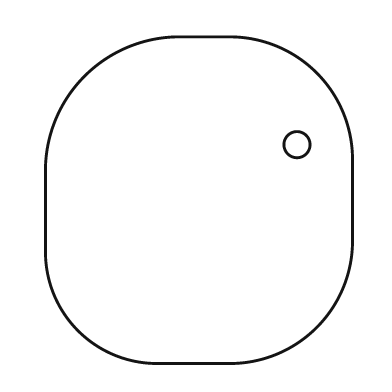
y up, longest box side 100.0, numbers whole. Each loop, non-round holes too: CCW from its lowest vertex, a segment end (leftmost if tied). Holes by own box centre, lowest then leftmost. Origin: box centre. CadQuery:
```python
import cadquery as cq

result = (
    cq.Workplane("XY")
    .moveTo(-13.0, -50.0)
    .lineTo(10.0, -50.0)
    .threePointArc((36.0, -39.0), (47.0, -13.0))
    .lineTo(47.0, 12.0)
    .threePointArc((36.0, 39.0), (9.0, 50.0))
    .lineTo(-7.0, 50.0)
    .threePointArc((-35.0, 38.0), (-47.0, 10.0))
    .lineTo(-47.0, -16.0)
    .threePointArc((-37.0, -40.0), (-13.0, -50.0))
    .close()
    .moveTo(30.0, 17.0)
    .circle(4.0)
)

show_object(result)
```